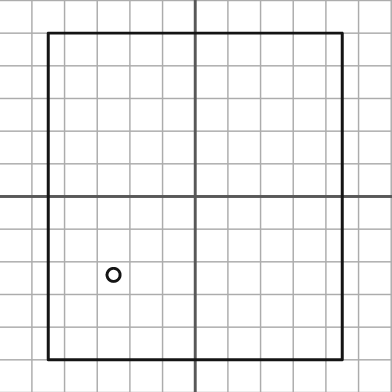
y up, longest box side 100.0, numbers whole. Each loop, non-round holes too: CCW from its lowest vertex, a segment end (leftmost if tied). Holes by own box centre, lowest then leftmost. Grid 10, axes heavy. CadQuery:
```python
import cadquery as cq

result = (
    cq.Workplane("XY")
    .moveTo(-45.0, -50.0)
    .lineTo(45.0, -50.0)
    .lineTo(45.0, 50.0)
    .lineTo(-45.0, 50.0)
    .close()
    .moveTo(-25.0, -24.0)
    .circle(2.0)
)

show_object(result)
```